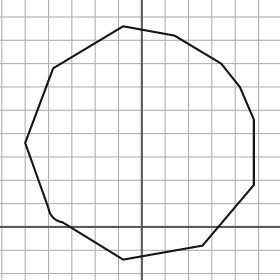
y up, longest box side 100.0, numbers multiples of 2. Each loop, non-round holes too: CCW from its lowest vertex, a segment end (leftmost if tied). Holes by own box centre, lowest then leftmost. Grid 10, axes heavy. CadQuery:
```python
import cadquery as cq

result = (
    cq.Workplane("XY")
    .moveTo(-8.0, -14.0)
    .lineTo(26.0, -8.0)
    .lineTo(48.0, 18.0)
    .lineTo(48.0, 46.0)
    .lineTo(42.0, 60.0)
    .lineTo(34.0, 70.0)
    .lineTo(14.0, 82.0)
    .lineTo(-8.0, 86.0)
    .lineTo(-38.0, 68.0)
    .lineTo(-50.0, 36.0)
    .lineTo(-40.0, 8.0)
    .threePointArc((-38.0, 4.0), (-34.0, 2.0))
    .close()
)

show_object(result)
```